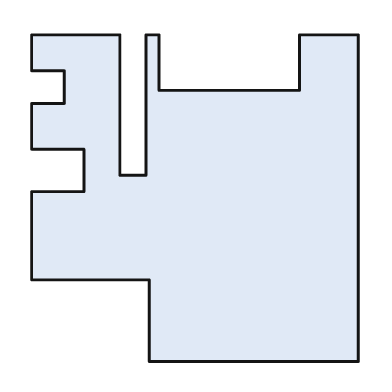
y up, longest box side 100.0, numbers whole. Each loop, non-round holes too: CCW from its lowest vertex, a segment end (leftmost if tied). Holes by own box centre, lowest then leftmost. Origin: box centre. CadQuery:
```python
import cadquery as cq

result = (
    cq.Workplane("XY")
    .moveTo(-14.0, -50.0)
    .lineTo(50.0, -50.0)
    .lineTo(50.0, 50.0)
    .lineTo(32.0, 50.0)
    .lineTo(32.0, 33.0)
    .lineTo(-11.0, 33.0)
    .lineTo(-11.0, 50.0)
    .lineTo(-15.0, 50.0)
    .lineTo(-15.0, 7.0)
    .lineTo(-23.0, 7.0)
    .lineTo(-23.0, 50.0)
    .lineTo(-50.0, 50.0)
    .lineTo(-50.0, 39.0)
    .lineTo(-40.0, 39.0)
    .lineTo(-40.0, 29.0)
    .lineTo(-50.0, 29.0)
    .lineTo(-50.0, 15.0)
    .lineTo(-34.0, 15.0)
    .lineTo(-34.0, 2.0)
    .lineTo(-50.0, 2.0)
    .lineTo(-50.0, -25.0)
    .lineTo(-14.0, -25.0)
    .close()
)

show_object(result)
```